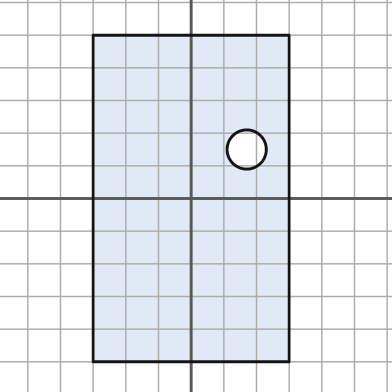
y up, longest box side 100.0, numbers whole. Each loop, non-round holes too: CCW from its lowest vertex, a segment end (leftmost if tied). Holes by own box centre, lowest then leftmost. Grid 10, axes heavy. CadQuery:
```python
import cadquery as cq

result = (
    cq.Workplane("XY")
    .moveTo(-30.0, -50.0)
    .lineTo(30.0, -50.0)
    .lineTo(30.0, 50.0)
    .lineTo(-30.0, 50.0)
    .close()
    .moveTo(17.0, 15.0)
    .circle(6.0)
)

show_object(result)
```